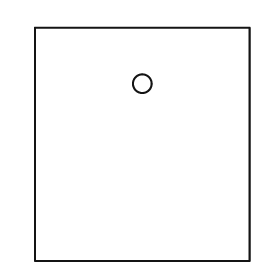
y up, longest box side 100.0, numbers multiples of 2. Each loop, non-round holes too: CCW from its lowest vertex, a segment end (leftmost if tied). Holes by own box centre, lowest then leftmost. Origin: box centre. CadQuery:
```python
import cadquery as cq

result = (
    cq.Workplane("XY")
    .moveTo(-46.0, -50.0)
    .lineTo(46.0, -50.0)
    .lineTo(46.0, 50.0)
    .lineTo(-46.0, 50.0)
    .close()
    .moveTo(0.0, 26.0)
    .circle(4.0)
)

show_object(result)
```